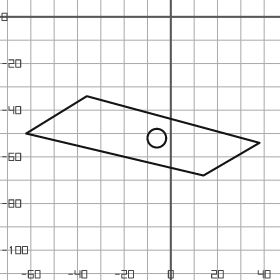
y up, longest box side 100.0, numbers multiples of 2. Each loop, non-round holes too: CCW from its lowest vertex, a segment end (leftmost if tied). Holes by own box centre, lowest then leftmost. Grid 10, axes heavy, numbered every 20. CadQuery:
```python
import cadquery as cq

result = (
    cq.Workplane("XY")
    .moveTo(14.0, -68.0)
    .lineTo(38.0, -54.0)
    .lineTo(-36.0, -34.0)
    .lineTo(-62.0, -50.0)
    .close()
    .moveTo(-6.0, -52.0)
    .circle(4.0)
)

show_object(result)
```